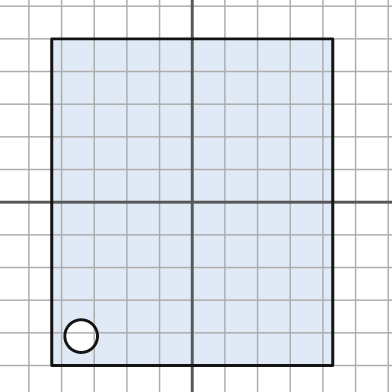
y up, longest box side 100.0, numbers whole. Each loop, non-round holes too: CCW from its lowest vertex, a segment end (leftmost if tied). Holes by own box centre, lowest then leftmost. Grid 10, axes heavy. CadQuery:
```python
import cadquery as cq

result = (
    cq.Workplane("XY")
    .moveTo(-43.0, -50.0)
    .lineTo(43.0, -50.0)
    .lineTo(43.0, 50.0)
    .lineTo(-43.0, 50.0)
    .close()
    .moveTo(-34.0, -41.0)
    .circle(5.0)
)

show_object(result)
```